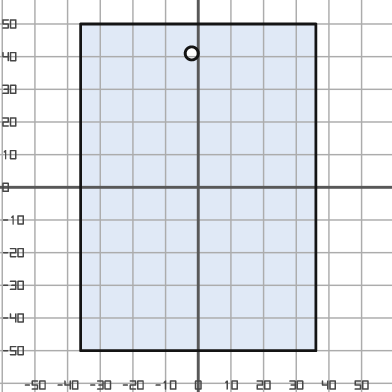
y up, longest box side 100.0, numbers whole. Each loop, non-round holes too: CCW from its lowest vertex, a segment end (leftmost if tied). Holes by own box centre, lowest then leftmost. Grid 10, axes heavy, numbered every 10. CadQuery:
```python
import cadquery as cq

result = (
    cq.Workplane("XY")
    .moveTo(-36.0, -50.0)
    .lineTo(36.0, -50.0)
    .lineTo(36.0, 50.0)
    .lineTo(-36.0, 50.0)
    .close()
    .moveTo(-2.0, 41.0)
    .circle(2.0)
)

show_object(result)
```